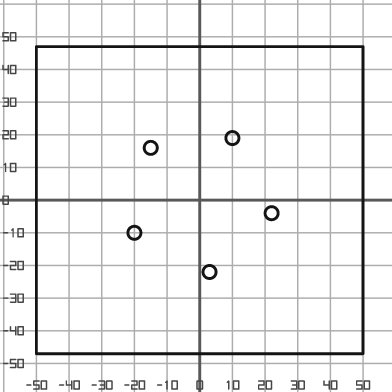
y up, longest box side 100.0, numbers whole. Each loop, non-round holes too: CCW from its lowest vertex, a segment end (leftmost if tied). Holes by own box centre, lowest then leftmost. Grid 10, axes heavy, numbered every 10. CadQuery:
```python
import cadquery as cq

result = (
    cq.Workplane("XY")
    .moveTo(-50.0, -47.0)
    .lineTo(50.0, -47.0)
    .lineTo(50.0, 47.0)
    .lineTo(-50.0, 47.0)
    .close()
    .moveTo(3.0, -22.0)
    .circle(2.0)
    .moveTo(-20.0, -10.0)
    .circle(2.0)
    .moveTo(22.0, -4.0)
    .circle(2.0)
    .moveTo(-15.0, 16.0)
    .circle(2.0)
    .moveTo(10.0, 19.0)
    .circle(2.0)
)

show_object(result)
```